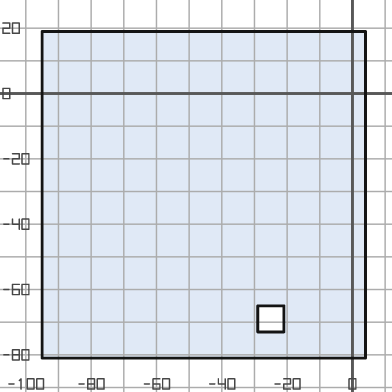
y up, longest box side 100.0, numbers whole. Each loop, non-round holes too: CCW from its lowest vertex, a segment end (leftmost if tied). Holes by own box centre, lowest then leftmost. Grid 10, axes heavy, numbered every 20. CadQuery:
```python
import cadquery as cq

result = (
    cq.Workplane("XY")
    .moveTo(-95.0, -81.0)
    .lineTo(4.0, -81.0)
    .lineTo(4.0, 19.0)
    .lineTo(-95.0, 19.0)
    .close()
    .moveTo(-29.0, -73.0)
    .lineTo(-21.0, -73.0)
    .lineTo(-21.0, -65.0)
    .lineTo(-29.0, -65.0)
    .close()
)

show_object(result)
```